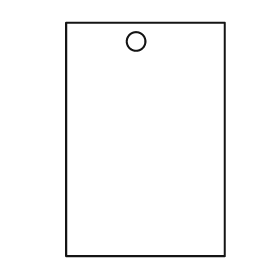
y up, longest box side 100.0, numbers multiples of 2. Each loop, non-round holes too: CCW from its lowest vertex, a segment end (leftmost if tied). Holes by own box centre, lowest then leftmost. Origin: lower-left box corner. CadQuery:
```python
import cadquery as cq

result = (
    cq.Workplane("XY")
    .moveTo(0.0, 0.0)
    .lineTo(68.0, 0.0)
    .lineTo(68.0, 100.0)
    .lineTo(0.0, 100.0)
    .close()
    .moveTo(30.0, 92.0)
    .circle(4.0)
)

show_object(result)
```